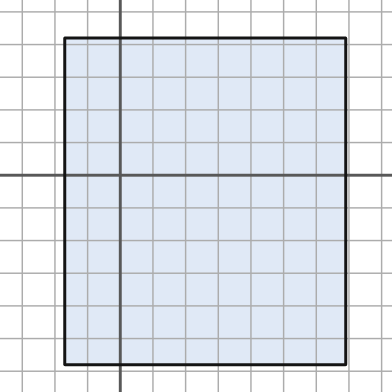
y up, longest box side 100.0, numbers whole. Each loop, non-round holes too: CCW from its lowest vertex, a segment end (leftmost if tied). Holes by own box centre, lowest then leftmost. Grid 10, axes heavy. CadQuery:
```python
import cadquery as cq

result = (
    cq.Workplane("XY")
    .moveTo(-17.0, -58.0)
    .lineTo(69.0, -58.0)
    .lineTo(69.0, 42.0)
    .lineTo(-17.0, 42.0)
    .close()
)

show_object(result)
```